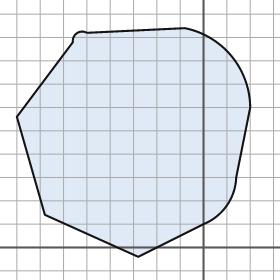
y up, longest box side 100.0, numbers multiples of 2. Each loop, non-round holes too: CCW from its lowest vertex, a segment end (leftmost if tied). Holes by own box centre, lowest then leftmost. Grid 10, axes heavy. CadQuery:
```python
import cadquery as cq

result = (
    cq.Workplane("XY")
    .moveTo(-28.0, -4.0)
    .lineTo(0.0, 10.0)
    .threePointArc((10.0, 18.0), (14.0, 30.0))
    .lineTo(20.0, 60.0)
    .threePointArc((12.0, 82.0), (-8.0, 94.0))
    .lineTo(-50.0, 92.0)
    .threePointArc((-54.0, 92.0), (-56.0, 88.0))
    .lineTo(-80.0, 56.0)
    .lineTo(-68.0, 14.0)
    .close()
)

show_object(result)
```